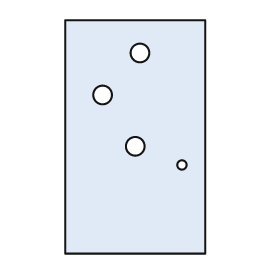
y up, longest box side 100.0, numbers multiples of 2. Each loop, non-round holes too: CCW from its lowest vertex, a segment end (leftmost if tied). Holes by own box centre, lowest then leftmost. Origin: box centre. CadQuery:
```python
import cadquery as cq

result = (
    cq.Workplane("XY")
    .moveTo(-30.0, -50.0)
    .lineTo(30.0, -50.0)
    .lineTo(30.0, 50.0)
    .lineTo(-30.0, 50.0)
    .close()
    .moveTo(20.0, -12.0)
    .circle(2.0)
    .moveTo(0.0, -4.0)
    .circle(4.0)
    .moveTo(-14.0, 18.0)
    .circle(4.0)
    .moveTo(2.0, 36.0)
    .circle(4.0)
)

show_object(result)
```